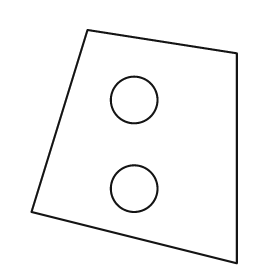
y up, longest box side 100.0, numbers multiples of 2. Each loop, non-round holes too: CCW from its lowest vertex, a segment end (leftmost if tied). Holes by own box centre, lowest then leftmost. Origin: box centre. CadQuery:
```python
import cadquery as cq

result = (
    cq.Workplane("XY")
    .moveTo(44.0, -50.0)
    .lineTo(44.0, 40.0)
    .lineTo(-20.0, 50.0)
    .lineTo(-44.0, -28.0)
    .close()
    .moveTo(0.0, -18.0)
    .circle(10.0)
    .moveTo(0.0, 20.0)
    .circle(10.0)
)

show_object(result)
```